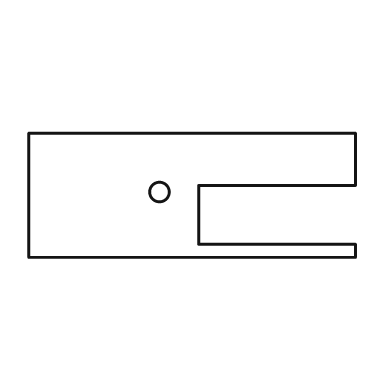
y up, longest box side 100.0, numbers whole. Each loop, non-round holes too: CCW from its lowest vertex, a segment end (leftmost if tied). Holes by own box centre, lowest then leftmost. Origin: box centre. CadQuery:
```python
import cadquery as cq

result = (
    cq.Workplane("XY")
    .moveTo(-50.0, -19.0)
    .lineTo(50.0, -19.0)
    .lineTo(50.0, -15.0)
    .lineTo(2.0, -15.0)
    .lineTo(2.0, 3.0)
    .lineTo(50.0, 3.0)
    .lineTo(50.0, 19.0)
    .lineTo(-50.0, 19.0)
    .close()
    .moveTo(-10.0, 1.0)
    .circle(3.0)
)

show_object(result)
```